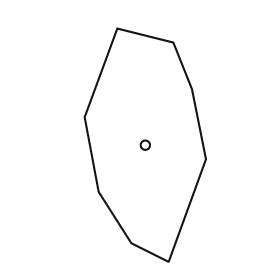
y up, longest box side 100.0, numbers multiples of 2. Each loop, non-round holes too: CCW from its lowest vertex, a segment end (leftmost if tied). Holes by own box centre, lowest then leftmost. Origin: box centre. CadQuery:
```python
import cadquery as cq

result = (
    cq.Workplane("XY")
    .moveTo(10.0, -50.0)
    .lineTo(26.0, -6.0)
    .lineTo(20.0, 24.0)
    .lineTo(12.0, 44.0)
    .lineTo(-12.0, 50.0)
    .lineTo(-26.0, 12.0)
    .lineTo(-20.0, -20.0)
    .lineTo(-6.0, -42.0)
    .close()
    .moveTo(0.0, 0.0)
    .circle(2.0)
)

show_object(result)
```